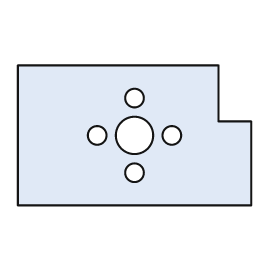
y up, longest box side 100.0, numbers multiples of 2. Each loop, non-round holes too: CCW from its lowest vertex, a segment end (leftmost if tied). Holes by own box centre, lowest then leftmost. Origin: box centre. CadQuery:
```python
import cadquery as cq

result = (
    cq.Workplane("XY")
    .moveTo(-50.0, -30.0)
    .lineTo(50.0, -30.0)
    .lineTo(50.0, 6.0)
    .lineTo(36.0, 6.0)
    .lineTo(36.0, 30.0)
    .lineTo(-50.0, 30.0)
    .close()
    .moveTo(0.0, -16.0)
    .circle(4.0)
    .moveTo(-16.0, 0.0)
    .circle(4.0)
    .moveTo(0.0, 0.0)
    .circle(8.0)
    .moveTo(16.0, 0.0)
    .circle(4.0)
    .moveTo(0.0, 16.0)
    .circle(4.0)
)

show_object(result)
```